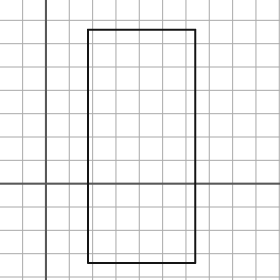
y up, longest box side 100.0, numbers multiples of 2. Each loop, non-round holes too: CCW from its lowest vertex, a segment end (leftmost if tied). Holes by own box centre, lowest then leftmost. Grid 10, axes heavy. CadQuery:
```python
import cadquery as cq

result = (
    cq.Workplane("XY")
    .moveTo(18.0, -34.0)
    .lineTo(64.0, -34.0)
    .lineTo(64.0, 66.0)
    .lineTo(18.0, 66.0)
    .close()
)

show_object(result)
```